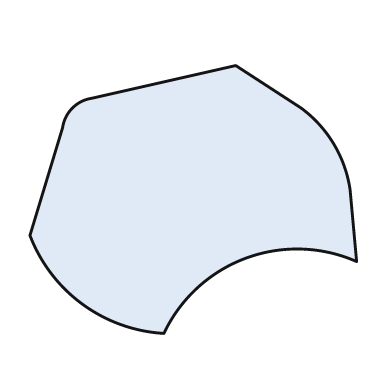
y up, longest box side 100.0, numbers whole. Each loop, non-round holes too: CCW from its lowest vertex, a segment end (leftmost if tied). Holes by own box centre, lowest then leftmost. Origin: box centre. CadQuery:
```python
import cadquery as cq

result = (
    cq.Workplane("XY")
    .moveTo(-9.0, -41.0)
    .threePointArc((16.0, -18.0), (50.0, -19.0))
    .lineTo(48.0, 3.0)
    .threePointArc((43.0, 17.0), (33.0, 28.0))
    .lineTo(13.0, 41.0)
    .lineTo(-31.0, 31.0)
    .threePointArc((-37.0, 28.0), (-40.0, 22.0))
    .lineTo(-50.0, -11.0)
    .threePointArc((-34.0, -32.0), (-9.0, -41.0))
    .close()
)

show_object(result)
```